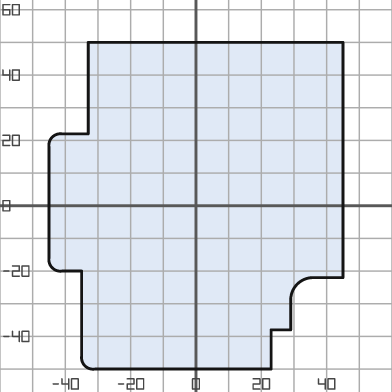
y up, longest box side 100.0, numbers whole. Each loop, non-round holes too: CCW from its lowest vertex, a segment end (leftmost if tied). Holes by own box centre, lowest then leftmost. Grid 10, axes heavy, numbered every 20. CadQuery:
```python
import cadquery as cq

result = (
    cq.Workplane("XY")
    .moveTo(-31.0, -50.0)
    .lineTo(23.0, -50.0)
    .lineTo(23.0, -38.0)
    .lineTo(29.0, -38.0)
    .lineTo(29.0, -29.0)
    .threePointArc((31.0, -24.0), (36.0, -22.0))
    .lineTo(45.0, -22.0)
    .lineTo(45.0, 50.0)
    .lineTo(-33.0, 50.0)
    .lineTo(-33.0, 22.0)
    .lineTo(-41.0, 22.0)
    .threePointArc((-44.0, 21.0), (-45.0, 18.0))
    .lineTo(-45.0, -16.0)
    .threePointArc((-44.0, -19.0), (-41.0, -20.0))
    .lineTo(-35.0, -20.0)
    .lineTo(-35.0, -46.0)
    .threePointArc((-34.0, -49.0), (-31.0, -50.0))
    .close()
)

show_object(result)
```